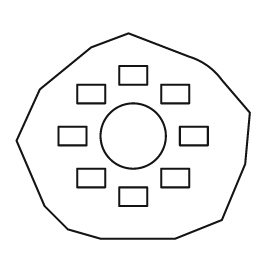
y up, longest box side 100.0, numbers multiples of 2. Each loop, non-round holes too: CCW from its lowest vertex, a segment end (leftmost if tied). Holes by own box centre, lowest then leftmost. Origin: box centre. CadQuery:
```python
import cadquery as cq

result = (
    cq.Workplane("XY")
    .moveTo(-14.0, -44.0)
    .lineTo(18.0, -44.0)
    .lineTo(38.0, -36.0)
    .lineTo(48.0, -12.0)
    .lineTo(50.0, 10.0)
    .lineTo(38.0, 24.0)
    .threePointArc((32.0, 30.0), (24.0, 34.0))
    .lineTo(-2.0, 44.0)
    .lineTo(-18.0, 38.0)
    .lineTo(-40.0, 20.0)
    .lineTo(-50.0, -2.0)
    .lineTo(-38.0, -30.0)
    .lineTo(-28.0, -40.0)
    .close()
    .moveTo(-6.0, -30.0)
    .lineTo(6.0, -30.0)
    .lineTo(6.0, -22.0)
    .lineTo(-6.0, -22.0)
    .close()
    .moveTo(-24.0, -22.0)
    .lineTo(-12.0, -22.0)
    .lineTo(-12.0, -14.0)
    .lineTo(-24.0, -14.0)
    .close()
    .moveTo(12.0, -22.0)
    .lineTo(24.0, -22.0)
    .lineTo(24.0, -14.0)
    .lineTo(12.0, -14.0)
    .close()
    .moveTo(-32.0, -4.0)
    .lineTo(-20.0, -4.0)
    .lineTo(-20.0, 4.0)
    .lineTo(-32.0, 4.0)
    .close()
    .moveTo(0.0, 0.0)
    .circle(14.0)
    .moveTo(20.0, -4.0)
    .lineTo(32.0, -4.0)
    .lineTo(32.0, 4.0)
    .lineTo(20.0, 4.0)
    .close()
    .moveTo(-24.0, 14.0)
    .lineTo(-12.0, 14.0)
    .lineTo(-12.0, 22.0)
    .lineTo(-24.0, 22.0)
    .close()
    .moveTo(12.0, 14.0)
    .lineTo(24.0, 14.0)
    .lineTo(24.0, 22.0)
    .lineTo(12.0, 22.0)
    .close()
    .moveTo(-6.0, 22.0)
    .lineTo(6.0, 22.0)
    .lineTo(6.0, 30.0)
    .lineTo(-6.0, 30.0)
    .close()
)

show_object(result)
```